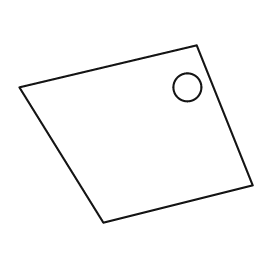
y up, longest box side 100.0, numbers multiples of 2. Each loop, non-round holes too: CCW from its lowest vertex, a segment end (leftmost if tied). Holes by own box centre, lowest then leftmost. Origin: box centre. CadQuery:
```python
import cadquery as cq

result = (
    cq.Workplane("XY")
    .moveTo(-14.0, -38.0)
    .lineTo(50.0, -22.0)
    .lineTo(26.0, 38.0)
    .lineTo(-50.0, 20.0)
    .close()
    .moveTo(22.0, 20.0)
    .circle(6.0)
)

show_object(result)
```